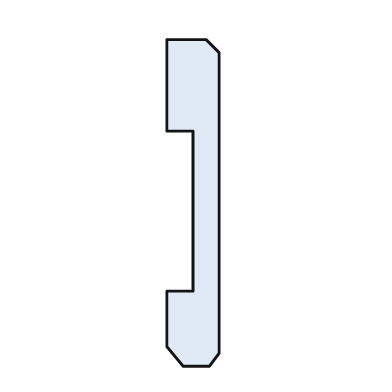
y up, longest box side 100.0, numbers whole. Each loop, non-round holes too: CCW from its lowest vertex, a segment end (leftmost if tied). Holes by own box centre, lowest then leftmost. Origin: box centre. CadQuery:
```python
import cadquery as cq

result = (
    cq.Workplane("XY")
    .moveTo(-3.0, -50.0)
    .lineTo(5.0, -50.0)
    .lineTo(8.0, -46.0)
    .lineTo(8.0, 46.0)
    .lineTo(4.0, 50.0)
    .lineTo(-8.0, 50.0)
    .lineTo(-8.0, 22.0)
    .lineTo(0.0, 22.0)
    .lineTo(0.0, -27.0)
    .lineTo(-8.0, -27.0)
    .lineTo(-8.0, -44.0)
    .close()
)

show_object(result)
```